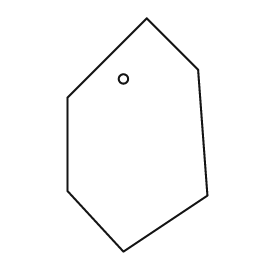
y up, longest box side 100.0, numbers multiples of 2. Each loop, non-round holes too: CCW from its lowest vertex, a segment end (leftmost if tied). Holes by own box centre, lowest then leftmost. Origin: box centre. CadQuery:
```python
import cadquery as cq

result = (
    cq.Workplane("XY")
    .moveTo(-6.0, -50.0)
    .lineTo(30.0, -26.0)
    .lineTo(26.0, 28.0)
    .lineTo(4.0, 50.0)
    .lineTo(-30.0, 16.0)
    .lineTo(-30.0, -24.0)
    .close()
    .moveTo(-6.0, 24.0)
    .circle(2.0)
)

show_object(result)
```